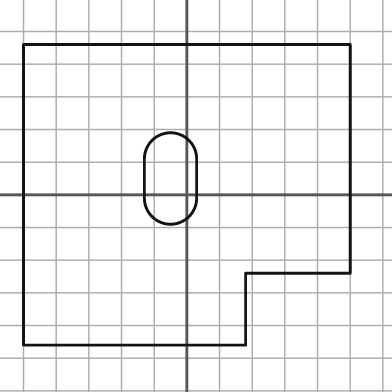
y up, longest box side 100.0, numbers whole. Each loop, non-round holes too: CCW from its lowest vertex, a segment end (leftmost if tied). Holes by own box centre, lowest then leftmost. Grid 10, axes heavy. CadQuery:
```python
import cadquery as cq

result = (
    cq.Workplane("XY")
    .moveTo(-50.0, -46.0)
    .lineTo(18.0, -46.0)
    .lineTo(18.0, -24.0)
    .lineTo(50.0, -24.0)
    .lineTo(50.0, 46.0)
    .lineTo(-50.0, 46.0)
    .close()
    .moveTo(-13.0, -1.0)
    .threePointArc((-5.0, -9.0), (3.0, -1.0))
    .lineTo(3.0, 11.0)
    .threePointArc((-5.0, 19.0), (-13.0, 11.0))
    .close()
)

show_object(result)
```